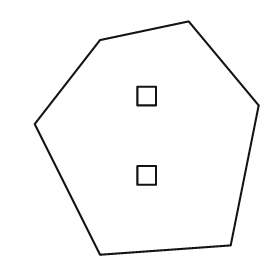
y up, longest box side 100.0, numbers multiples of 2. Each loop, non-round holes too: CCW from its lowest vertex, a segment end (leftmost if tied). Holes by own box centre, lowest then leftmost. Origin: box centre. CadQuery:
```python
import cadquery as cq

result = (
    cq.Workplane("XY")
    .moveTo(-20.0, -50.0)
    .lineTo(36.0, -46.0)
    .lineTo(48.0, 14.0)
    .lineTo(18.0, 50.0)
    .lineTo(-20.0, 42.0)
    .lineTo(-48.0, 6.0)
    .close()
    .moveTo(-4.0, -20.0)
    .lineTo(4.0, -20.0)
    .lineTo(4.0, -12.0)
    .lineTo(-4.0, -12.0)
    .close()
    .moveTo(-4.0, 14.0)
    .lineTo(4.0, 14.0)
    .lineTo(4.0, 22.0)
    .lineTo(-4.0, 22.0)
    .close()
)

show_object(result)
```